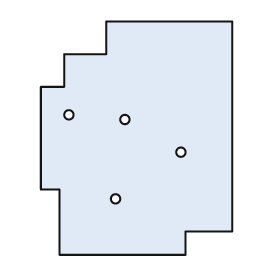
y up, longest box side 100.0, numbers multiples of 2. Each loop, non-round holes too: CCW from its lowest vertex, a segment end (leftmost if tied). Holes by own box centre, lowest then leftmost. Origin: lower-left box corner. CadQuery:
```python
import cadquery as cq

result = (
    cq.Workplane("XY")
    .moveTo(8.0, 0.0)
    .lineTo(62.0, 0.0)
    .lineTo(62.0, 10.0)
    .lineTo(82.0, 10.0)
    .lineTo(82.0, 100.0)
    .lineTo(28.0, 100.0)
    .lineTo(28.0, 86.0)
    .lineTo(10.0, 86.0)
    .lineTo(10.0, 72.0)
    .lineTo(0.0, 72.0)
    .lineTo(0.0, 28.0)
    .lineTo(8.0, 28.0)
    .close()
    .moveTo(32.0, 24.0)
    .circle(2.0)
    .moveTo(60.0, 44.0)
    .circle(2.0)
    .moveTo(36.0, 58.0)
    .circle(2.0)
    .moveTo(12.0, 60.0)
    .circle(2.0)
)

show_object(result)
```